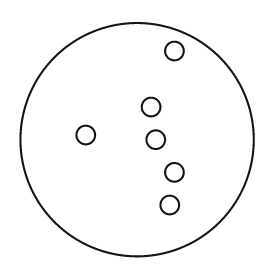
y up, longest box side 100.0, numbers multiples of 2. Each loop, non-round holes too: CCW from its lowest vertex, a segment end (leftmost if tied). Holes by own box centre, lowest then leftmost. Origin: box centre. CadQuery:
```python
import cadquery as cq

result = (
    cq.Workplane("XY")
    .moveTo(0.0, 0.0)
    .circle(50.0)
    .moveTo(14.0, -28.0)
    .circle(4.0)
    .moveTo(16.0, -14.0)
    .circle(4.0)
    .moveTo(8.0, 0.0)
    .circle(4.0)
    .moveTo(-22.0, 2.0)
    .circle(4.0)
    .moveTo(6.0, 14.0)
    .circle(4.0)
    .moveTo(16.0, 38.0)
    .circle(4.0)
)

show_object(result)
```